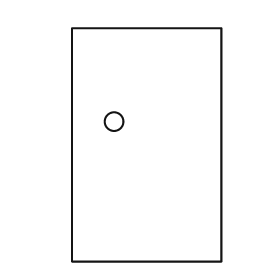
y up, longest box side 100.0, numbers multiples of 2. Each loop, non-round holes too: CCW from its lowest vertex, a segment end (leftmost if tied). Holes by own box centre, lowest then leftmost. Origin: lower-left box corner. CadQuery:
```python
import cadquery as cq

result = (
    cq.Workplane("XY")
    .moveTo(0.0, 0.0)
    .lineTo(64.0, 0.0)
    .lineTo(64.0, 100.0)
    .lineTo(0.0, 100.0)
    .close()
    .moveTo(18.0, 60.0)
    .circle(4.0)
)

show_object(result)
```